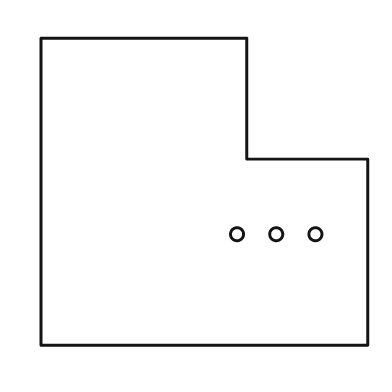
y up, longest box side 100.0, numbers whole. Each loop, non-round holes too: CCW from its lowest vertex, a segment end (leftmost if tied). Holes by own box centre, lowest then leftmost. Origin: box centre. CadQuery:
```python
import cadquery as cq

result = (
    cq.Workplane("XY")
    .moveTo(-50.0, -47.0)
    .lineTo(50.0, -47.0)
    .lineTo(50.0, 10.0)
    .lineTo(13.0, 10.0)
    .lineTo(13.0, 47.0)
    .lineTo(-50.0, 47.0)
    .close()
    .moveTo(10.0, -13.0)
    .circle(2.0)
    .moveTo(22.0, -13.0)
    .circle(2.0)
    .moveTo(34.0, -13.0)
    .circle(2.0)
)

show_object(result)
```